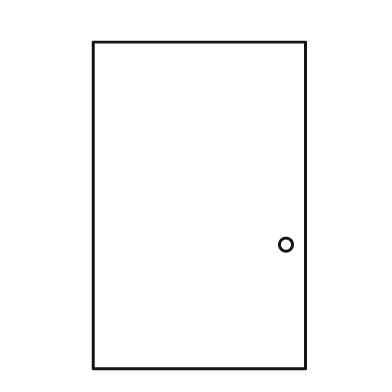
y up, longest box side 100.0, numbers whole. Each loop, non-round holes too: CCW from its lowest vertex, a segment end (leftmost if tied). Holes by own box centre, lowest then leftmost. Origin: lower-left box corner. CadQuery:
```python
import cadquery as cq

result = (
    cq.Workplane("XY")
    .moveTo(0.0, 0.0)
    .lineTo(65.0, 0.0)
    .lineTo(65.0, 100.0)
    .lineTo(0.0, 100.0)
    .close()
    .moveTo(59.0, 38.0)
    .circle(2.0)
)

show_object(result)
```